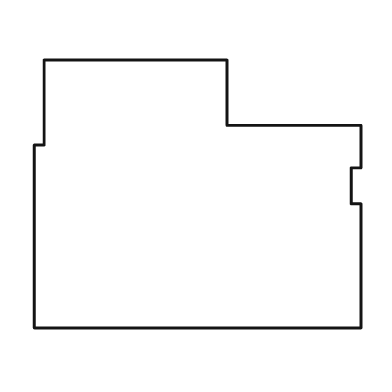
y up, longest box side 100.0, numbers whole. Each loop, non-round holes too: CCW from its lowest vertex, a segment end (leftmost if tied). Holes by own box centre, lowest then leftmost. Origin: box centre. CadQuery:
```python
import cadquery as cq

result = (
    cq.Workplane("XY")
    .moveTo(-50.0, -41.0)
    .lineTo(50.0, -41.0)
    .lineTo(50.0, -3.0)
    .lineTo(47.0, -3.0)
    .lineTo(47.0, 8.0)
    .lineTo(50.0, 8.0)
    .lineTo(50.0, 21.0)
    .lineTo(9.0, 21.0)
    .lineTo(9.0, 41.0)
    .lineTo(-47.0, 41.0)
    .lineTo(-47.0, 15.0)
    .lineTo(-50.0, 15.0)
    .close()
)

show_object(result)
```